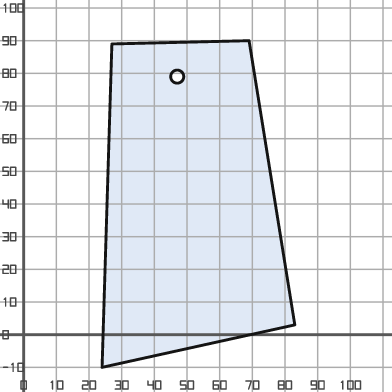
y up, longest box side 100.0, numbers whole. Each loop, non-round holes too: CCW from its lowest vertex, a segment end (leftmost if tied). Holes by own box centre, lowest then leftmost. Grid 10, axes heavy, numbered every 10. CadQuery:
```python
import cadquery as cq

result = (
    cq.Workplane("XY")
    .moveTo(24.0, -10.0)
    .lineTo(83.0, 3.0)
    .lineTo(69.0, 90.0)
    .lineTo(27.0, 89.0)
    .close()
    .moveTo(47.0, 79.0)
    .circle(2.0)
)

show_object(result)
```